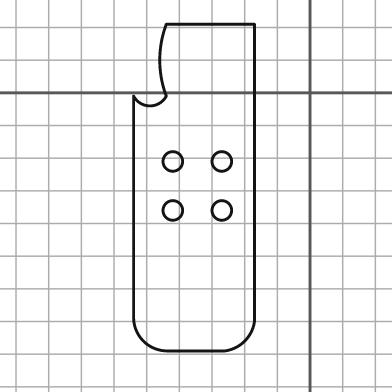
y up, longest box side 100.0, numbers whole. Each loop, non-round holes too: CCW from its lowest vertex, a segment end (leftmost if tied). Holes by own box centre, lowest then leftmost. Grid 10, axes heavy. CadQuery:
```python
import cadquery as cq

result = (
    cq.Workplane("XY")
    .moveTo(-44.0, -79.0)
    .lineTo(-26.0, -79.0)
    .threePointArc((-20.0, -76.0), (-17.0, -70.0))
    .lineTo(-17.0, 21.0)
    .lineTo(-44.0, 21.0)
    .threePointArc((-46.0, 10.0), (-44.0, -1.0))
    .threePointArc((-49.0, -4.0), (-54.0, -1.0))
    .lineTo(-54.0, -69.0)
    .threePointArc((-51.0, -76.0), (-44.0, -79.0))
    .close()
    .moveTo(-42.0, -36.0)
    .circle(3.0)
    .moveTo(-27.0, -36.0)
    .circle(3.0)
    .moveTo(-42.0, -21.0)
    .circle(3.0)
    .moveTo(-27.0, -21.0)
    .circle(3.0)
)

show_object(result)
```